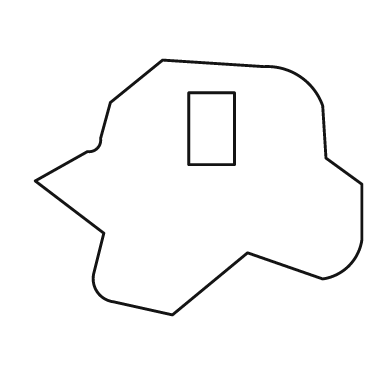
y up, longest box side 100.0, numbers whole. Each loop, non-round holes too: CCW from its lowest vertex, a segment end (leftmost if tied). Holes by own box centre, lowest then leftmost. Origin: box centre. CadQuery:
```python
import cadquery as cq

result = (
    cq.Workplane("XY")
    .moveTo(-8.0, -39.0)
    .lineTo(15.0, -20.0)
    .lineTo(38.0, -28.0)
    .threePointArc((46.0, -24.0), (50.0, -16.0))
    .lineTo(50.0, 1.0)
    .lineTo(39.0, 9.0)
    .lineTo(38.0, 25.0)
    .threePointArc((31.0, 34.0), (20.0, 37.0))
    .lineTo(-11.0, 39.0)
    .lineTo(-27.0, 26.0)
    .lineTo(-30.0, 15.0)
    .threePointArc((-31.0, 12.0), (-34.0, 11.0))
    .lineTo(-50.0, 2.0)
    .lineTo(-29.0, -14.0)
    .lineTo(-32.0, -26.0)
    .threePointArc((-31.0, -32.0), (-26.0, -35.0))
    .close()
    .moveTo(-3.0, 7.0)
    .lineTo(11.0, 7.0)
    .lineTo(11.0, 29.0)
    .lineTo(-3.0, 29.0)
    .close()
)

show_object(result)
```